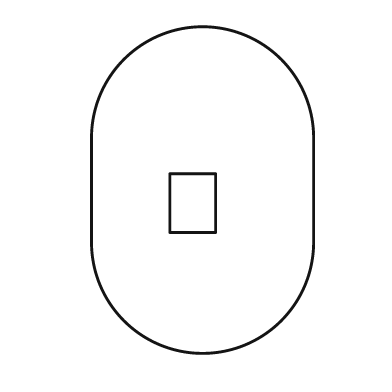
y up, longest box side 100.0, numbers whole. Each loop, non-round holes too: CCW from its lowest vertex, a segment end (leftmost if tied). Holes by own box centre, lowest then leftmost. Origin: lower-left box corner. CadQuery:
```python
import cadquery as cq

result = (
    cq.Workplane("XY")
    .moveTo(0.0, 34.0)
    .threePointArc((34.0, 0.0), (68.0, 34.0))
    .lineTo(68.0, 66.0)
    .threePointArc((34.0, 100.0), (0.0, 66.0))
    .close()
    .moveTo(24.0, 37.0)
    .lineTo(38.0, 37.0)
    .lineTo(38.0, 55.0)
    .lineTo(24.0, 55.0)
    .close()
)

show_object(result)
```